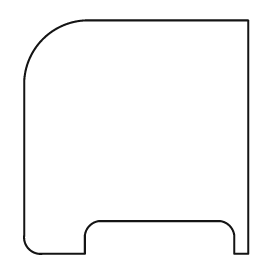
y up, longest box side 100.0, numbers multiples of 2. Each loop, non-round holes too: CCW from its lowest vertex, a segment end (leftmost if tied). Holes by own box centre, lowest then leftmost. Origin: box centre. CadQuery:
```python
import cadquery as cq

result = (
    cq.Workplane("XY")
    .moveTo(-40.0, -50.0)
    .lineTo(-22.0, -50.0)
    .lineTo(-22.0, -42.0)
    .threePointArc((-20.0, -38.0), (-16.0, -36.0))
    .lineTo(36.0, -36.0)
    .threePointArc((40.0, -38.0), (42.0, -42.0))
    .lineTo(42.0, -50.0)
    .lineTo(48.0, -50.0)
    .lineTo(48.0, 50.0)
    .lineTo(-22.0, 50.0)
    .threePointArc((-40.0, 42.0), (-48.0, 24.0))
    .lineTo(-48.0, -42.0)
    .threePointArc((-46.0, -48.0), (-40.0, -50.0))
    .close()
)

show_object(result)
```